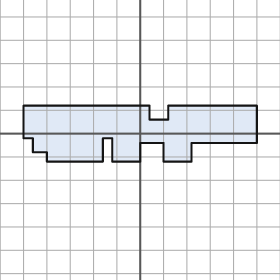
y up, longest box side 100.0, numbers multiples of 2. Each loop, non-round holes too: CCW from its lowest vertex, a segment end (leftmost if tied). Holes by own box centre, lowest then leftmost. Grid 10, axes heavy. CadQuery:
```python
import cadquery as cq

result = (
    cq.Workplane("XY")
    .moveTo(-40.0, -12.0)
    .lineTo(-16.0, -12.0)
    .lineTo(-16.0, -2.0)
    .lineTo(-12.0, -2.0)
    .lineTo(-12.0, -12.0)
    .lineTo(0.0, -12.0)
    .lineTo(0.0, -4.0)
    .lineTo(10.0, -4.0)
    .lineTo(10.0, -12.0)
    .lineTo(22.0, -12.0)
    .lineTo(22.0, -4.0)
    .lineTo(50.0, -4.0)
    .lineTo(50.0, 12.0)
    .lineTo(12.0, 12.0)
    .lineTo(12.0, 6.0)
    .lineTo(4.0, 6.0)
    .lineTo(4.0, 12.0)
    .lineTo(-50.0, 12.0)
    .lineTo(-50.0, -2.0)
    .lineTo(-46.0, -2.0)
    .lineTo(-46.0, -8.0)
    .lineTo(-40.0, -8.0)
    .close()
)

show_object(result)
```